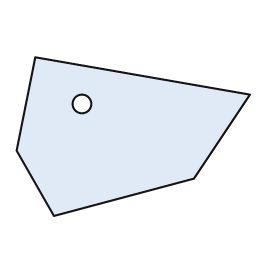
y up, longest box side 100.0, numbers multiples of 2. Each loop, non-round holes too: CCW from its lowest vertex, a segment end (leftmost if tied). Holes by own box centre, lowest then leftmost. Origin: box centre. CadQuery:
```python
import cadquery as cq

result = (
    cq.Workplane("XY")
    .moveTo(-34.0, -34.0)
    .lineTo(26.0, -18.0)
    .lineTo(50.0, 18.0)
    .lineTo(-42.0, 34.0)
    .lineTo(-50.0, -6.0)
    .close()
    .moveTo(-22.0, 14.0)
    .circle(4.0)
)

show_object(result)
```